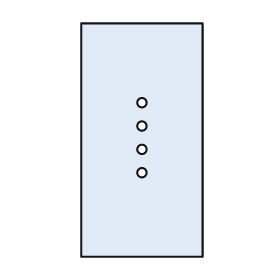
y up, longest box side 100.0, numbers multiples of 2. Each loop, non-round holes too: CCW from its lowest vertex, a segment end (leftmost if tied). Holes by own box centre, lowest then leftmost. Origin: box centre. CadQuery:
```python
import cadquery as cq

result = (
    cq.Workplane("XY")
    .moveTo(-26.0, -50.0)
    .lineTo(26.0, -50.0)
    .lineTo(26.0, 50.0)
    .lineTo(-26.0, 50.0)
    .close()
    .moveTo(0.0, -14.0)
    .circle(2.0)
    .moveTo(0.0, -4.0)
    .circle(2.0)
    .moveTo(0.0, 6.0)
    .circle(2.0)
    .moveTo(0.0, 16.0)
    .circle(2.0)
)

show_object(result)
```